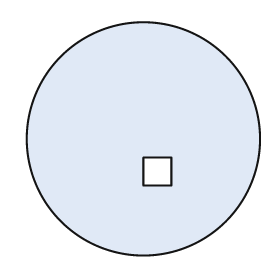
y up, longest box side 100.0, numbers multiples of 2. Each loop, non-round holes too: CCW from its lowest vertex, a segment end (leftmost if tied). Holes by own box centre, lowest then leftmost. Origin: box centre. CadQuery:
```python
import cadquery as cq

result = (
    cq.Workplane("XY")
    .moveTo(0.0, 0.0)
    .circle(50.0)
    .moveTo(0.0, -20.0)
    .lineTo(12.0, -20.0)
    .lineTo(12.0, -8.0)
    .lineTo(0.0, -8.0)
    .close()
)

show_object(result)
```